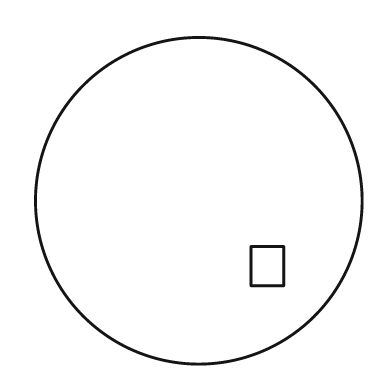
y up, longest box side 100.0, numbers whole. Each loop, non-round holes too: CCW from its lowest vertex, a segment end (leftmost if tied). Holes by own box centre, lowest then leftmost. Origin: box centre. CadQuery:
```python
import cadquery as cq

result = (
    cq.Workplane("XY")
    .moveTo(0.0, 0.0)
    .circle(50.0)
    .moveTo(16.0, -26.0)
    .lineTo(26.0, -26.0)
    .lineTo(26.0, -14.0)
    .lineTo(16.0, -14.0)
    .close()
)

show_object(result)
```